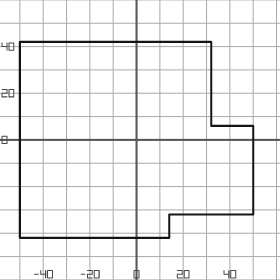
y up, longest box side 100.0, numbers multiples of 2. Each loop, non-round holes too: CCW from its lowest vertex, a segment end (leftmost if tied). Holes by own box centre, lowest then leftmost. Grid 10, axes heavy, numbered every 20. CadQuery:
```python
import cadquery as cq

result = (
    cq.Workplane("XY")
    .moveTo(-50.0, -42.0)
    .lineTo(14.0, -42.0)
    .lineTo(14.0, -32.0)
    .lineTo(50.0, -32.0)
    .lineTo(50.0, 6.0)
    .lineTo(32.0, 6.0)
    .lineTo(32.0, 42.0)
    .lineTo(-50.0, 42.0)
    .close()
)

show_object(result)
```